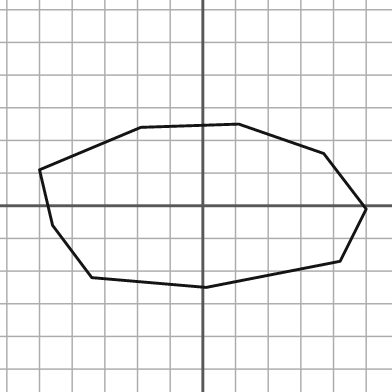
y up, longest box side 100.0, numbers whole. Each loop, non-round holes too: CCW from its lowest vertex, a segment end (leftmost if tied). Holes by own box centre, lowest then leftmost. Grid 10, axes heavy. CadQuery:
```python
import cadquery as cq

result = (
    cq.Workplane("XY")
    .moveTo(1.0, -25.0)
    .lineTo(42.0, -17.0)
    .lineTo(50.0, -1.0)
    .lineTo(37.0, 16.0)
    .lineTo(11.0, 25.0)
    .lineTo(-19.0, 24.0)
    .lineTo(-50.0, 11.0)
    .lineTo(-46.0, -6.0)
    .lineTo(-34.0, -22.0)
    .close()
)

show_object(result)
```